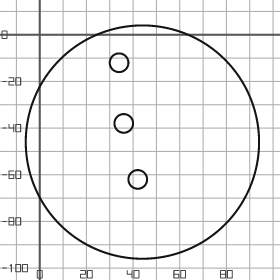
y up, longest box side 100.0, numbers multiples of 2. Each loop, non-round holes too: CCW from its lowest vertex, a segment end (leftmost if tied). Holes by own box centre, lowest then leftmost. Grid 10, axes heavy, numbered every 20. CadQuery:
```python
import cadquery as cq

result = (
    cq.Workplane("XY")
    .moveTo(44.0, -46.0)
    .circle(50.0)
    .moveTo(42.0, -62.0)
    .circle(4.0)
    .moveTo(36.0, -38.0)
    .circle(4.0)
    .moveTo(34.0, -12.0)
    .circle(4.0)
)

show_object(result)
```